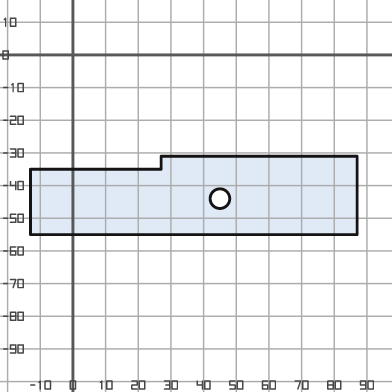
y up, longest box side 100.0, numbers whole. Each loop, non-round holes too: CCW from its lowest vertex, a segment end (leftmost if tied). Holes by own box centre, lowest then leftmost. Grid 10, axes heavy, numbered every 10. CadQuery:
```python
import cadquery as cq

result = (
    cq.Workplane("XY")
    .moveTo(-13.0, -55.0)
    .lineTo(87.0, -55.0)
    .lineTo(87.0, -31.0)
    .lineTo(27.0, -31.0)
    .lineTo(27.0, -35.0)
    .lineTo(-13.0, -35.0)
    .close()
    .moveTo(45.0, -44.0)
    .circle(3.0)
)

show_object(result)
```